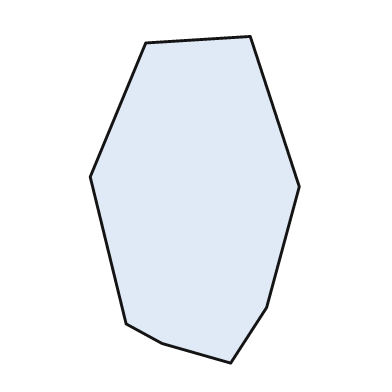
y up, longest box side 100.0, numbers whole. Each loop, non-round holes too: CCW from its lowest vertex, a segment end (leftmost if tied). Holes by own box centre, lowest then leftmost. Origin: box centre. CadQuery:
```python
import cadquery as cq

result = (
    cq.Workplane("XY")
    .moveTo(11.0, -50.0)
    .lineTo(22.0, -33.0)
    .lineTo(32.0, 4.0)
    .lineTo(17.0, 50.0)
    .lineTo(-15.0, 48.0)
    .lineTo(-32.0, 7.0)
    .lineTo(-21.0, -38.0)
    .lineTo(-10.0, -44.0)
    .close()
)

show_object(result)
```